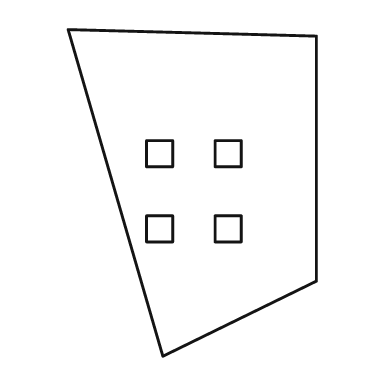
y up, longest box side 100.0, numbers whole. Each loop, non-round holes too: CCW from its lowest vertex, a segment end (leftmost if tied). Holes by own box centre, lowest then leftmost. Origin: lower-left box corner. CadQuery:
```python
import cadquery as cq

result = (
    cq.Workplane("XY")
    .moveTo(29.0, 0.0)
    .lineTo(76.0, 23.0)
    .lineTo(76.0, 98.0)
    .lineTo(0.0, 100.0)
    .close()
    .moveTo(24.0, 35.0)
    .lineTo(32.0, 35.0)
    .lineTo(32.0, 43.0)
    .lineTo(24.0, 43.0)
    .close()
    .moveTo(45.0, 35.0)
    .lineTo(53.0, 35.0)
    .lineTo(53.0, 43.0)
    .lineTo(45.0, 43.0)
    .close()
    .moveTo(24.0, 58.0)
    .lineTo(32.0, 58.0)
    .lineTo(32.0, 66.0)
    .lineTo(24.0, 66.0)
    .close()
    .moveTo(45.0, 58.0)
    .lineTo(53.0, 58.0)
    .lineTo(53.0, 66.0)
    .lineTo(45.0, 66.0)
    .close()
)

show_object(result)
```